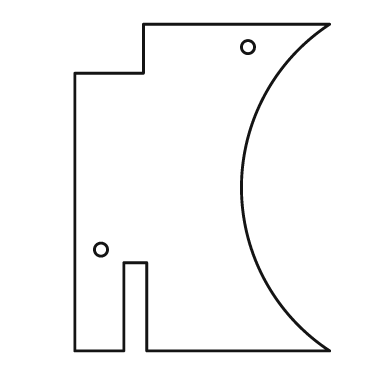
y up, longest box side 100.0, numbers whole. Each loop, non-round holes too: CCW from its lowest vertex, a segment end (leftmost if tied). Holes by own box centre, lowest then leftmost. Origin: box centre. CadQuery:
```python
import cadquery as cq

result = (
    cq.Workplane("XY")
    .moveTo(-39.0, -50.0)
    .lineTo(-24.0, -50.0)
    .lineTo(-24.0, -23.0)
    .lineTo(-17.0, -23.0)
    .lineTo(-17.0, -50.0)
    .lineTo(39.0, -50.0)
    .threePointArc((12.0, 0.0), (39.0, 50.0))
    .lineTo(-18.0, 50.0)
    .lineTo(-18.0, 35.0)
    .lineTo(-39.0, 35.0)
    .close()
    .moveTo(-31.0, -19.0)
    .circle(2.0)
    .moveTo(14.0, 43.0)
    .circle(2.0)
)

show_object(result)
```